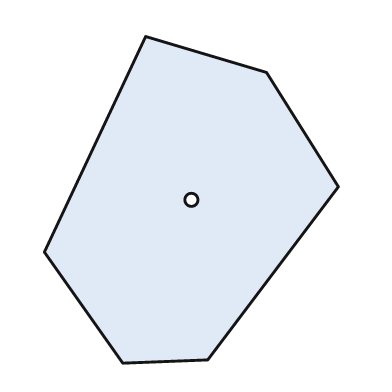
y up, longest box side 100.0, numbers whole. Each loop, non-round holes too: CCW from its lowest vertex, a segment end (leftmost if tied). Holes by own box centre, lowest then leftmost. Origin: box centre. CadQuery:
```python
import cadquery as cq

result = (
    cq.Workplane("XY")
    .moveTo(-21.0, -50.0)
    .lineTo(5.0, -49.0)
    .lineTo(45.0, 4.0)
    .lineTo(23.0, 39.0)
    .lineTo(-14.0, 50.0)
    .lineTo(-45.0, -16.0)
    .close()
    .moveTo(0.0, 0.0)
    .circle(2.0)
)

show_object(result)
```